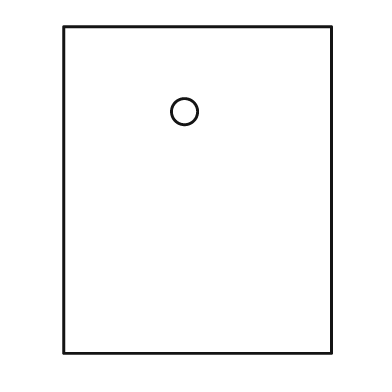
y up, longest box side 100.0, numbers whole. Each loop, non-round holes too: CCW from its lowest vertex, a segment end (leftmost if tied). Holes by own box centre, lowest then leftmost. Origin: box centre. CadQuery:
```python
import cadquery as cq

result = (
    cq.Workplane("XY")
    .moveTo(-41.0, -50.0)
    .lineTo(41.0, -50.0)
    .lineTo(41.0, 50.0)
    .lineTo(-41.0, 50.0)
    .close()
    .moveTo(-4.0, 24.0)
    .circle(4.0)
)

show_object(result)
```